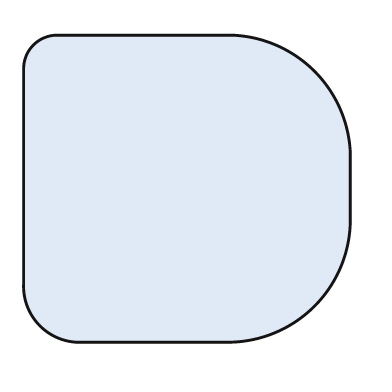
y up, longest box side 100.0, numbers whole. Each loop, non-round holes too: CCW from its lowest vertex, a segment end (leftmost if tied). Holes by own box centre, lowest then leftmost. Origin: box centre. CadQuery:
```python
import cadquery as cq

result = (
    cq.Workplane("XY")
    .moveTo(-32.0, -47.0)
    .lineTo(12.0, -47.0)
    .threePointArc((39.0, -36.0), (50.0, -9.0))
    .lineTo(50.0, 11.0)
    .threePointArc((39.0, 36.0), (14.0, 47.0))
    .lineTo(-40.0, 47.0)
    .threePointArc((-47.0, 44.0), (-50.0, 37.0))
    .lineTo(-50.0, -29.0)
    .threePointArc((-45.0, -42.0), (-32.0, -47.0))
    .close()
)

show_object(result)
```